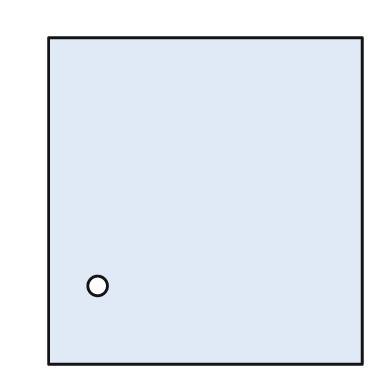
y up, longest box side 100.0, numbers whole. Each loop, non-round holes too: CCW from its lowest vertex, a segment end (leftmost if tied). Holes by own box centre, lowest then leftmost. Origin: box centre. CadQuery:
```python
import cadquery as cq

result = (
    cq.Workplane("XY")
    .moveTo(-48.0, -50.0)
    .lineTo(48.0, -50.0)
    .lineTo(48.0, 50.0)
    .lineTo(-48.0, 50.0)
    .close()
    .moveTo(-33.0, -26.0)
    .circle(3.0)
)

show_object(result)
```